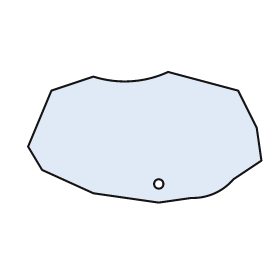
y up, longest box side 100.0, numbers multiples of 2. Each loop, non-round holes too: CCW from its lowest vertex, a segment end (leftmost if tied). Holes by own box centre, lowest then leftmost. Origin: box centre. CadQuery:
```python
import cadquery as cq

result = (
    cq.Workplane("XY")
    .moveTo(6.0, -28.0)
    .lineTo(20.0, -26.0)
    .threePointArc((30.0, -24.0), (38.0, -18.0))
    .lineTo(50.0, -10.0)
    .lineTo(48.0, 4.0)
    .lineTo(40.0, 20.0)
    .lineTo(10.0, 28.0)
    .threePointArc((-6.0, 24.0), (-22.0, 26.0))
    .lineTo(-40.0, 20.0)
    .lineTo(-50.0, -4.0)
    .lineTo(-44.0, -14.0)
    .lineTo(-22.0, -24.0)
    .close()
    .moveTo(6.0, -20.0)
    .circle(2.0)
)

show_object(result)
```